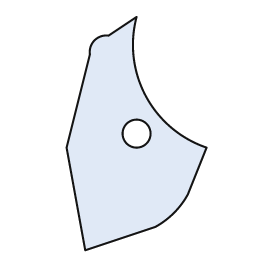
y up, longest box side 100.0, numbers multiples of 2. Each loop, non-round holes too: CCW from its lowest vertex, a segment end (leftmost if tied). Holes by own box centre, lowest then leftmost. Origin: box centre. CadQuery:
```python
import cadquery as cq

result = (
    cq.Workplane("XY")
    .moveTo(-22.0, -50.0)
    .lineTo(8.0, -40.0)
    .threePointArc((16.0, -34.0), (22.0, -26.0))
    .lineTo(30.0, -6.0)
    .threePointArc((4.0, 16.0), (0.0, 50.0))
    .lineTo(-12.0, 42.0)
    .threePointArc((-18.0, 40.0), (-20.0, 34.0))
    .lineTo(-30.0, -6.0)
    .close()
    .moveTo(0.0, 0.0)
    .circle(6.0)
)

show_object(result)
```